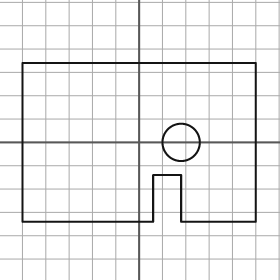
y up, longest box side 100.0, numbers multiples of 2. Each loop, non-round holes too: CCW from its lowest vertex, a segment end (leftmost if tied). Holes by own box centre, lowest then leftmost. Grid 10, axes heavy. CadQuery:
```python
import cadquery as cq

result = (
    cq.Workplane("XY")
    .moveTo(-50.0, -34.0)
    .lineTo(6.0, -34.0)
    .lineTo(6.0, -14.0)
    .lineTo(18.0, -14.0)
    .lineTo(18.0, -34.0)
    .lineTo(50.0, -34.0)
    .lineTo(50.0, 34.0)
    .lineTo(-50.0, 34.0)
    .close()
    .moveTo(18.0, 0.0)
    .circle(8.0)
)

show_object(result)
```